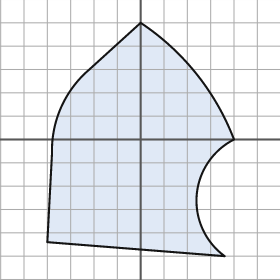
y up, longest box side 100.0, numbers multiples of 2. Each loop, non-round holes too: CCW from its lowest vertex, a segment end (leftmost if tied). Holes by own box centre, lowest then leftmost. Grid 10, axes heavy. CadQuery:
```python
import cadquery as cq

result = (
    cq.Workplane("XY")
    .moveTo(36.0, -50.0)
    .threePointArc((24.0, -24.0), (40.0, 0.0))
    .threePointArc((24.0, 28.0), (0.0, 50.0))
    .lineTo(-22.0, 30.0)
    .threePointArc((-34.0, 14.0), (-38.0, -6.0))
    .lineTo(-40.0, -44.0)
    .close()
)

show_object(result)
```